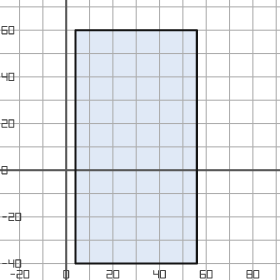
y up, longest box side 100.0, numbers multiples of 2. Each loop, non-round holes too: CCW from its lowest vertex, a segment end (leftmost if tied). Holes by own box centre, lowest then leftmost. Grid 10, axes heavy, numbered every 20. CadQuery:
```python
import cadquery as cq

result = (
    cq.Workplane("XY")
    .moveTo(4.0, -40.0)
    .lineTo(56.0, -40.0)
    .lineTo(56.0, 60.0)
    .lineTo(4.0, 60.0)
    .close()
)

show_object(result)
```